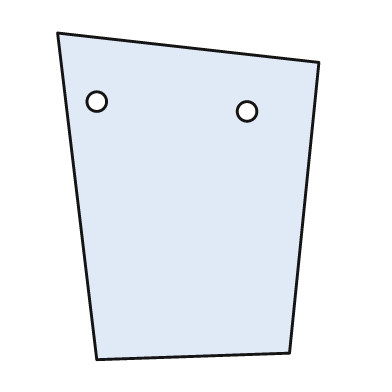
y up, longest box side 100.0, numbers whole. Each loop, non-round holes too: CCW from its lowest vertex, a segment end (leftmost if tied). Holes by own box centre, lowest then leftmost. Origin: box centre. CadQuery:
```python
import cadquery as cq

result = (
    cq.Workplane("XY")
    .moveTo(-28.0, -50.0)
    .lineTo(31.0, -48.0)
    .lineTo(40.0, 41.0)
    .lineTo(-40.0, 50.0)
    .close()
    .moveTo(18.0, 26.0)
    .circle(3.0)
    .moveTo(-28.0, 29.0)
    .circle(3.0)
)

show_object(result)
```